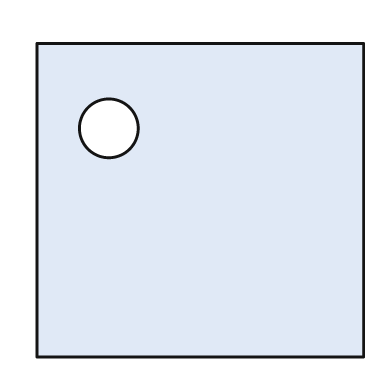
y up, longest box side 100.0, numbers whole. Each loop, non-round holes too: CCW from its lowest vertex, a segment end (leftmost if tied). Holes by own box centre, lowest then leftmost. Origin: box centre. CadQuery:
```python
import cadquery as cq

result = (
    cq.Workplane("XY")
    .moveTo(-50.0, -48.0)
    .lineTo(50.0, -48.0)
    .lineTo(50.0, 48.0)
    .lineTo(-50.0, 48.0)
    .close()
    .moveTo(-28.0, 22.0)
    .circle(9.0)
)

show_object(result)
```